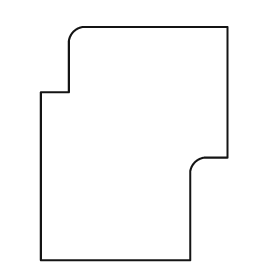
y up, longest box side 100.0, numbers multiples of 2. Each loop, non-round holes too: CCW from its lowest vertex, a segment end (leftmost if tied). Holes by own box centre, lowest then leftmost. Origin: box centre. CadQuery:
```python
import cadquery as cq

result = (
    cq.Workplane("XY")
    .moveTo(-40.0, -50.0)
    .lineTo(24.0, -50.0)
    .lineTo(24.0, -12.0)
    .threePointArc((26.0, -8.0), (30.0, -6.0))
    .lineTo(40.0, -6.0)
    .lineTo(40.0, 50.0)
    .lineTo(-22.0, 50.0)
    .threePointArc((-26.0, 48.0), (-28.0, 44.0))
    .lineTo(-28.0, 22.0)
    .lineTo(-40.0, 22.0)
    .close()
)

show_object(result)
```